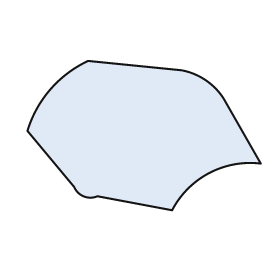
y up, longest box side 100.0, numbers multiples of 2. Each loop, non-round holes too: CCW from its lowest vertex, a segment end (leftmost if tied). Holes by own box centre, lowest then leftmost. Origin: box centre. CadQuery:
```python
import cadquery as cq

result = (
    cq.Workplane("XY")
    .moveTo(12.0, -32.0)
    .threePointArc((28.0, -16.0), (50.0, -12.0))
    .lineTo(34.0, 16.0)
    .threePointArc((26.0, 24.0), (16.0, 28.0))
    .lineTo(-24.0, 32.0)
    .threePointArc((-40.0, 20.0), (-50.0, 2.0))
    .lineTo(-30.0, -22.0)
    .threePointArc((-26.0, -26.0), (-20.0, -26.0))
    .close()
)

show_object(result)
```